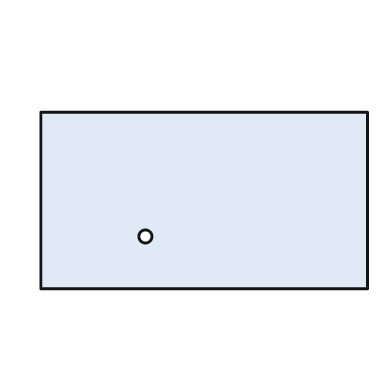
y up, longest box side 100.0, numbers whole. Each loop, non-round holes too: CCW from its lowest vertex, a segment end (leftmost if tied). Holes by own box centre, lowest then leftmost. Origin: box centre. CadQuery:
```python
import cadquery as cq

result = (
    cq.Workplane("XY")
    .moveTo(-50.0, -27.0)
    .lineTo(50.0, -27.0)
    .lineTo(50.0, 27.0)
    .lineTo(-50.0, 27.0)
    .close()
    .moveTo(-18.0, -11.0)
    .circle(2.0)
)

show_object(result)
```